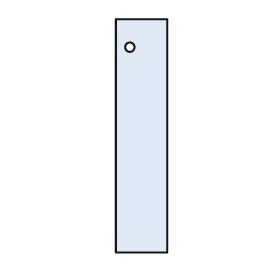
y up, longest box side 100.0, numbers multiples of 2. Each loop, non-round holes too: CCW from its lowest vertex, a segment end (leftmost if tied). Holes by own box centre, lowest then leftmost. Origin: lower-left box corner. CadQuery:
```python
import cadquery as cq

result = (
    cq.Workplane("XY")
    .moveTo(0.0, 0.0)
    .lineTo(22.0, 0.0)
    .lineTo(22.0, 100.0)
    .lineTo(0.0, 100.0)
    .close()
    .moveTo(6.0, 88.0)
    .circle(2.0)
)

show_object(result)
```